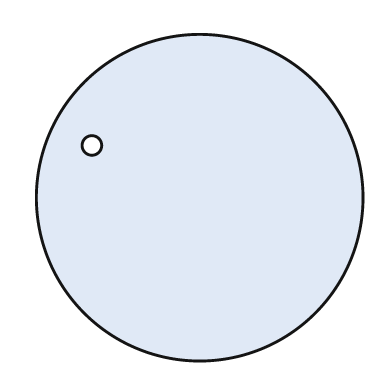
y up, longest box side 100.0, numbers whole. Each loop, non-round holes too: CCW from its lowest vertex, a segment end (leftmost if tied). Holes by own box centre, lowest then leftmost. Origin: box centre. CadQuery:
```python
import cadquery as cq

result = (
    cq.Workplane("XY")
    .moveTo(0.0, 0.0)
    .circle(50.0)
    .moveTo(-33.0, 16.0)
    .circle(3.0)
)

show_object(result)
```